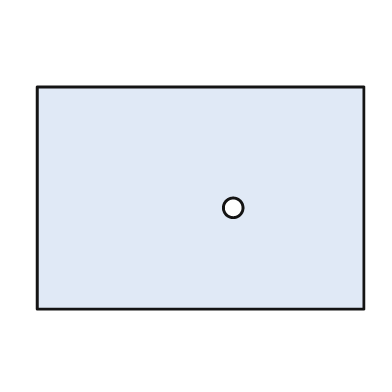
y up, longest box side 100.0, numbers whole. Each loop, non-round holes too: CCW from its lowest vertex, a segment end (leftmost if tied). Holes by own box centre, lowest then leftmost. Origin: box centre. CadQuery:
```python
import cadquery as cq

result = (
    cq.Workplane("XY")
    .moveTo(-50.0, -34.0)
    .lineTo(50.0, -34.0)
    .lineTo(50.0, 34.0)
    .lineTo(-50.0, 34.0)
    .close()
    .moveTo(10.0, -3.0)
    .circle(3.0)
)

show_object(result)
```